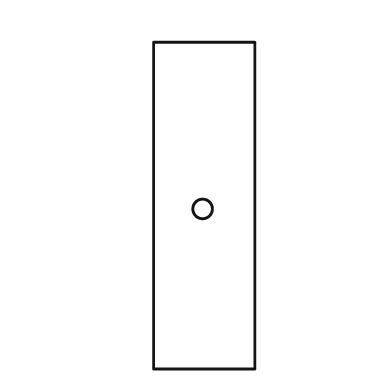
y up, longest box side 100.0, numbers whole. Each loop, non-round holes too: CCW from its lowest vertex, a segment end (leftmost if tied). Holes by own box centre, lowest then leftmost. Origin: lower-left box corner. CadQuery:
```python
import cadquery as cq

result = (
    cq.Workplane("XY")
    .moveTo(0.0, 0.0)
    .lineTo(31.0, 0.0)
    .lineTo(31.0, 100.0)
    .lineTo(0.0, 100.0)
    .close()
    .moveTo(15.0, 49.0)
    .circle(3.0)
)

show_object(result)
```